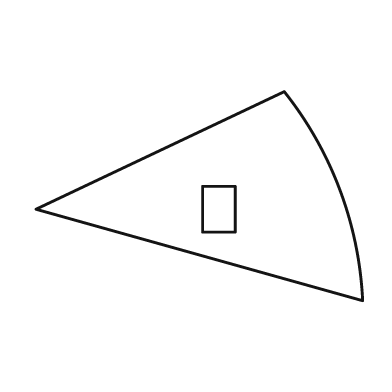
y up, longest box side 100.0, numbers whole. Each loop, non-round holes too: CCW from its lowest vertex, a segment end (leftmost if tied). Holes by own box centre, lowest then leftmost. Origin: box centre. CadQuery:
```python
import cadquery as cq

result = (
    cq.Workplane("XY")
    .moveTo(50.0, -32.0)
    .threePointArc((43.0, 2.0), (26.0, 32.0))
    .lineTo(-50.0, -4.0)
    .close()
    .moveTo(1.0, -11.0)
    .lineTo(11.0, -11.0)
    .lineTo(11.0, 3.0)
    .lineTo(1.0, 3.0)
    .close()
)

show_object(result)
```